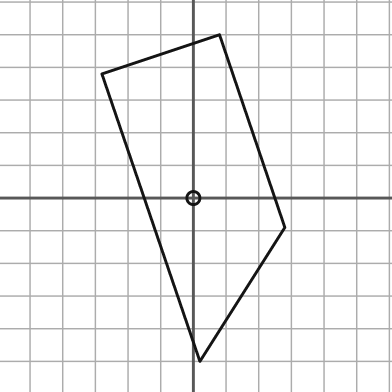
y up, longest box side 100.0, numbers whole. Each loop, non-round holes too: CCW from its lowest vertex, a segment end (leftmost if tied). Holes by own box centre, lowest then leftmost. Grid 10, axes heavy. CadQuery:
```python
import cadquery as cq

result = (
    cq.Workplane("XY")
    .moveTo(2.0, -50.0)
    .lineTo(28.0, -9.0)
    .lineTo(8.0, 50.0)
    .lineTo(-28.0, 38.0)
    .close()
    .moveTo(0.0, 0.0)
    .circle(2.0)
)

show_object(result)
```